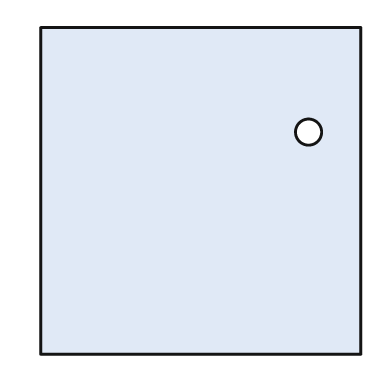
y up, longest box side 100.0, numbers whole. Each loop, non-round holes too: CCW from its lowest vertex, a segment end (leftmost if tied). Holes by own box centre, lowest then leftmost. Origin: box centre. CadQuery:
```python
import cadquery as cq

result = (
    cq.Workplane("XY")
    .moveTo(-49.0, -50.0)
    .lineTo(49.0, -50.0)
    .lineTo(49.0, 50.0)
    .lineTo(-49.0, 50.0)
    .close()
    .moveTo(33.0, 18.0)
    .circle(4.0)
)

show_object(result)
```